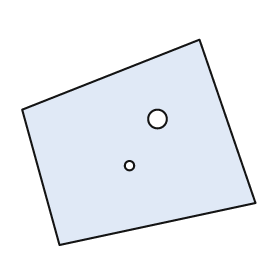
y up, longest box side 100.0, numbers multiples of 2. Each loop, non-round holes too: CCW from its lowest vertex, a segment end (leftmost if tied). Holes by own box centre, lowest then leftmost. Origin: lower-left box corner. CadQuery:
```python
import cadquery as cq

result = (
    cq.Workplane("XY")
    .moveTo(16.0, 0.0)
    .lineTo(100.0, 18.0)
    .lineTo(76.0, 88.0)
    .lineTo(0.0, 58.0)
    .close()
    .moveTo(46.0, 34.0)
    .circle(2.0)
    .moveTo(58.0, 54.0)
    .circle(4.0)
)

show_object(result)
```